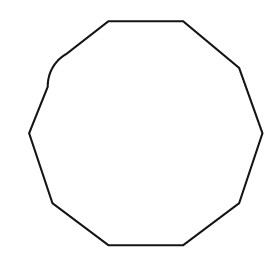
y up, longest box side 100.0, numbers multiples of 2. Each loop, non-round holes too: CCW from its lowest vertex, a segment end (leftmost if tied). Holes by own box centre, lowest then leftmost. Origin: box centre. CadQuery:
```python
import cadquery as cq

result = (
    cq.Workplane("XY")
    .moveTo(-16.0, -48.0)
    .lineTo(16.0, -48.0)
    .lineTo(40.0, -30.0)
    .lineTo(50.0, 0.0)
    .lineTo(40.0, 28.0)
    .lineTo(16.0, 48.0)
    .lineTo(-16.0, 48.0)
    .lineTo(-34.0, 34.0)
    .threePointArc((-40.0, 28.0), (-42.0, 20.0))
    .lineTo(-50.0, 0.0)
    .lineTo(-40.0, -30.0)
    .close()
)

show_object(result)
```